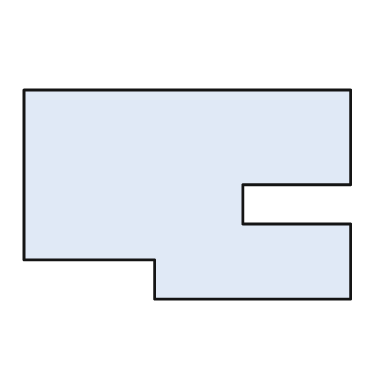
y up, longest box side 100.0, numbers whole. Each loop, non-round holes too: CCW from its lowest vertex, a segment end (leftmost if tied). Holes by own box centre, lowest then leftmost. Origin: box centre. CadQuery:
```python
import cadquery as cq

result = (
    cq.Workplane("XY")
    .moveTo(-10.0, -32.0)
    .lineTo(50.0, -32.0)
    .lineTo(50.0, -9.0)
    .lineTo(17.0, -9.0)
    .lineTo(17.0, 3.0)
    .lineTo(50.0, 3.0)
    .lineTo(50.0, 32.0)
    .lineTo(-50.0, 32.0)
    .lineTo(-50.0, -20.0)
    .lineTo(-10.0, -20.0)
    .close()
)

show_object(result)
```